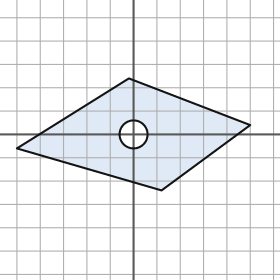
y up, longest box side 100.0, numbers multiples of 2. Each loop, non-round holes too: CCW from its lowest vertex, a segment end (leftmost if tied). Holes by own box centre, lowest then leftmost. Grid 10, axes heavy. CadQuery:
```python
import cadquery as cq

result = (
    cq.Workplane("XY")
    .moveTo(12.0, -24.0)
    .lineTo(50.0, 4.0)
    .lineTo(-2.0, 24.0)
    .lineTo(-50.0, -6.0)
    .close()
    .moveTo(0.0, 0.0)
    .circle(6.0)
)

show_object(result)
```